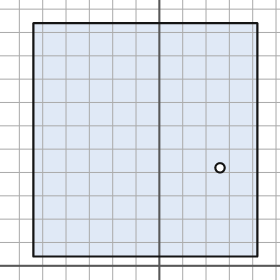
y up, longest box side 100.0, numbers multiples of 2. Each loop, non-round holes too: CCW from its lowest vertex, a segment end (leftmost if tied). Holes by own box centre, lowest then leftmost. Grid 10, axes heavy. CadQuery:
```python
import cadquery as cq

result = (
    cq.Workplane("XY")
    .moveTo(-54.0, 4.0)
    .lineTo(42.0, 4.0)
    .lineTo(42.0, 104.0)
    .lineTo(-54.0, 104.0)
    .close()
    .moveTo(26.0, 42.0)
    .circle(2.0)
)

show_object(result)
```